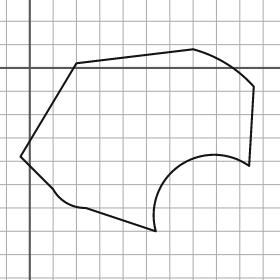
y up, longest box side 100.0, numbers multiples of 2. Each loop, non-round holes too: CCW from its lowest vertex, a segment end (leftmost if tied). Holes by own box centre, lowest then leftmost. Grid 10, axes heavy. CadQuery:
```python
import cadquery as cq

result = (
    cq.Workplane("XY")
    .moveTo(54.0, -70.0)
    .threePointArc((64.0, -42.0), (94.0, -42.0))
    .lineTo(96.0, -8.0)
    .threePointArc((84.0, 2.0), (70.0, 8.0))
    .lineTo(20.0, 2.0)
    .lineTo(-4.0, -38.0)
    .lineTo(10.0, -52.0)
    .threePointArc((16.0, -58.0), (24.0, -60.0))
    .close()
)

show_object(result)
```